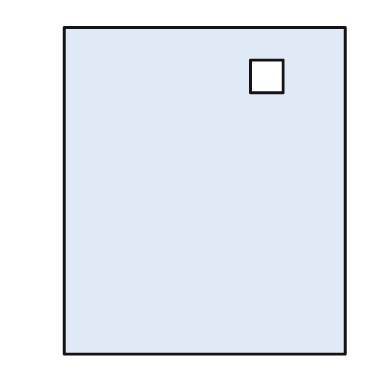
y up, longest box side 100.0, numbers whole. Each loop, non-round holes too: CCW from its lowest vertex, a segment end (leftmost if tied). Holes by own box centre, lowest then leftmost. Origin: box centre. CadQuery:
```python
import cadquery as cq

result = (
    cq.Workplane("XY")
    .moveTo(-43.0, -50.0)
    .lineTo(43.0, -50.0)
    .lineTo(43.0, 50.0)
    .lineTo(-43.0, 50.0)
    .close()
    .moveTo(14.0, 30.0)
    .lineTo(24.0, 30.0)
    .lineTo(24.0, 40.0)
    .lineTo(14.0, 40.0)
    .close()
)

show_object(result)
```